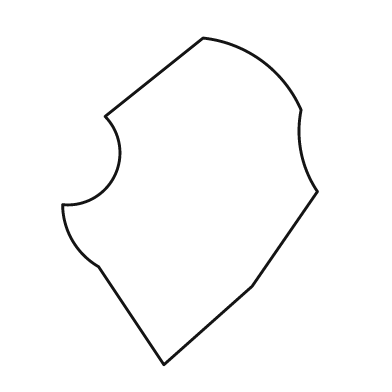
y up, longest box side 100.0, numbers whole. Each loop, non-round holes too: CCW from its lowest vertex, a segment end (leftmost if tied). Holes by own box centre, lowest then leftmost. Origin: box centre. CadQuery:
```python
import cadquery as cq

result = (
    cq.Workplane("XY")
    .moveTo(-8.0, -50.0)
    .lineTo(19.0, -26.0)
    .lineTo(39.0, 3.0)
    .threePointArc((34.0, 15.0), (34.0, 28.0))
    .threePointArc((22.0, 43.0), (4.0, 50.0))
    .lineTo(-26.0, 26.0)
    .threePointArc((-23.0, 8.0), (-39.0, -1.0))
    .threePointArc((-36.0, -12.0), (-28.0, -20.0))
    .close()
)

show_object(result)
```